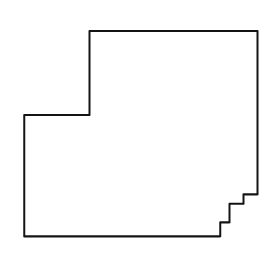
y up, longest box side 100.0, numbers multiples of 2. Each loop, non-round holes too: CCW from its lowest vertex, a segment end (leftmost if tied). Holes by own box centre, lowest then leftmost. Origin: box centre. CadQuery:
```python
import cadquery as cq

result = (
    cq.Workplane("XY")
    .moveTo(-50.0, -44.0)
    .lineTo(34.0, -44.0)
    .lineTo(34.0, -38.0)
    .lineTo(38.0, -38.0)
    .lineTo(38.0, -30.0)
    .lineTo(44.0, -30.0)
    .lineTo(44.0, -26.0)
    .lineTo(50.0, -26.0)
    .lineTo(50.0, 44.0)
    .lineTo(-22.0, 44.0)
    .lineTo(-22.0, 8.0)
    .lineTo(-50.0, 8.0)
    .close()
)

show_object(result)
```